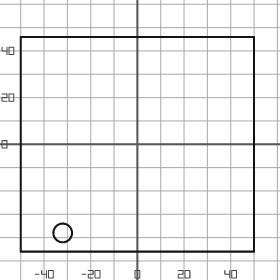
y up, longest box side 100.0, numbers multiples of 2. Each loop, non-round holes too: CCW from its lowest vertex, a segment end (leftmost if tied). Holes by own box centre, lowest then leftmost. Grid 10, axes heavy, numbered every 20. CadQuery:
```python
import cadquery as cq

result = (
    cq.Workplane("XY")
    .moveTo(-50.0, -46.0)
    .lineTo(50.0, -46.0)
    .lineTo(50.0, 46.0)
    .lineTo(-50.0, 46.0)
    .close()
    .moveTo(-32.0, -38.0)
    .circle(4.0)
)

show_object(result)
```